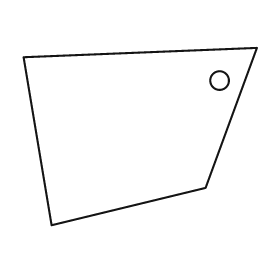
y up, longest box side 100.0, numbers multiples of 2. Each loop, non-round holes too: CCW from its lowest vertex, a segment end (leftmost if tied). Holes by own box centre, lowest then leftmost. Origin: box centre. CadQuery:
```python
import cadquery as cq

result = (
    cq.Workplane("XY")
    .moveTo(-38.0, -38.0)
    .lineTo(28.0, -22.0)
    .lineTo(50.0, 38.0)
    .lineTo(-50.0, 34.0)
    .close()
    .moveTo(34.0, 24.0)
    .circle(4.0)
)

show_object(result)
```